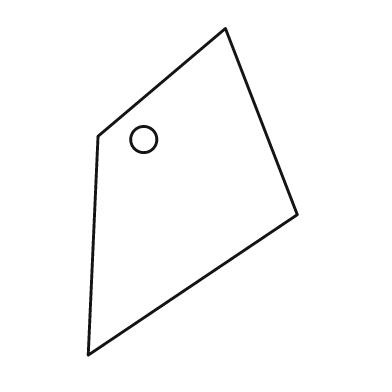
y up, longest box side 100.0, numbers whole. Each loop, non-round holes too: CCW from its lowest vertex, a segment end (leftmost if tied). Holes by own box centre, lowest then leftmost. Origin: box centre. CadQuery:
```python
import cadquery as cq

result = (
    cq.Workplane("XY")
    .moveTo(-32.0, -50.0)
    .lineTo(32.0, -7.0)
    .lineTo(10.0, 50.0)
    .lineTo(-29.0, 17.0)
    .close()
    .moveTo(-15.0, 16.0)
    .circle(4.0)
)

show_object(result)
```